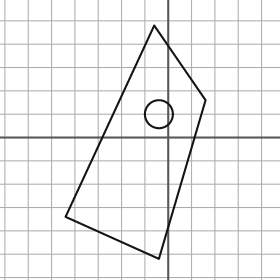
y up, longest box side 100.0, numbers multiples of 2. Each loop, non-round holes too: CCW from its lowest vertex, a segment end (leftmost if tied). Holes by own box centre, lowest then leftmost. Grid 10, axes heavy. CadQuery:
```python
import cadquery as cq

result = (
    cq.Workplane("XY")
    .moveTo(-4.0, -52.0)
    .lineTo(16.0, 16.0)
    .lineTo(-6.0, 48.0)
    .lineTo(-44.0, -34.0)
    .close()
    .moveTo(-4.0, 10.0)
    .circle(6.0)
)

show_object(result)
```